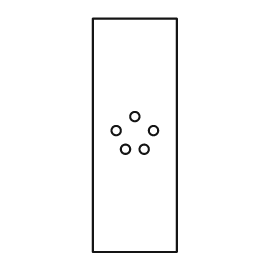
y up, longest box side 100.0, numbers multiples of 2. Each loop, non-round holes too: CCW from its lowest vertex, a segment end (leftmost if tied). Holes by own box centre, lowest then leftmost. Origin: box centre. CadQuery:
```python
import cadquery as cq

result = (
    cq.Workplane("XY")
    .moveTo(-18.0, -50.0)
    .lineTo(18.0, -50.0)
    .lineTo(18.0, 50.0)
    .lineTo(-18.0, 50.0)
    .close()
    .moveTo(-4.0, -6.0)
    .circle(2.0)
    .moveTo(4.0, -6.0)
    .circle(2.0)
    .moveTo(-8.0, 2.0)
    .circle(2.0)
    .moveTo(8.0, 2.0)
    .circle(2.0)
    .moveTo(0.0, 8.0)
    .circle(2.0)
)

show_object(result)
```